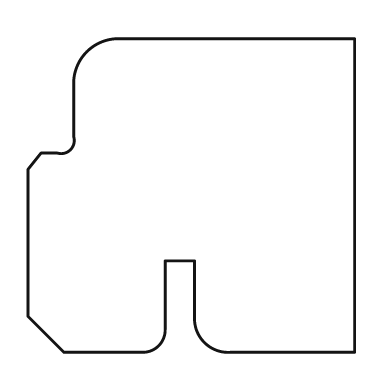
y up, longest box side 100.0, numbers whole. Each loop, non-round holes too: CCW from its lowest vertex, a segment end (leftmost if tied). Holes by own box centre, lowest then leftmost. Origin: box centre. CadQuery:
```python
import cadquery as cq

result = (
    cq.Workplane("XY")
    .moveTo(-39.0, -48.0)
    .lineTo(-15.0, -48.0)
    .threePointArc((-10.0, -46.0), (-8.0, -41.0))
    .lineTo(-8.0, -20.0)
    .lineTo(1.0, -20.0)
    .lineTo(1.0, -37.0)
    .threePointArc((4.0, -45.0), (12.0, -48.0))
    .lineTo(50.0, -48.0)
    .lineTo(50.0, 48.0)
    .lineTo(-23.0, 48.0)
    .threePointArc((-32.0, 44.0), (-36.0, 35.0))
    .lineTo(-36.0, 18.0)
    .threePointArc((-37.0, 14.0), (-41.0, 13.0))
    .lineTo(-46.0, 13.0)
    .lineTo(-50.0, 8.0)
    .lineTo(-50.0, -37.0)
    .close()
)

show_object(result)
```